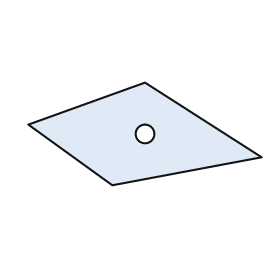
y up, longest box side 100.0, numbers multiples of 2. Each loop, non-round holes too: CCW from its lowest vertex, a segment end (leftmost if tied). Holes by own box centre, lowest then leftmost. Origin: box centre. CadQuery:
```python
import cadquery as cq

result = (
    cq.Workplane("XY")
    .moveTo(-14.0, -22.0)
    .lineTo(50.0, -10.0)
    .lineTo(0.0, 22.0)
    .lineTo(-50.0, 4.0)
    .close()
    .moveTo(0.0, 0.0)
    .circle(4.0)
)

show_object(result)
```